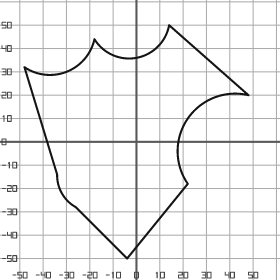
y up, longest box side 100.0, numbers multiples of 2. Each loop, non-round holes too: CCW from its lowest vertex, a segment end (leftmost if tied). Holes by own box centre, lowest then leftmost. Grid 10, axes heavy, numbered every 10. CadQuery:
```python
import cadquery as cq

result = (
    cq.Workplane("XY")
    .moveTo(-4.0, -50.0)
    .lineTo(22.0, -18.0)
    .threePointArc((22.0, 10.0), (48.0, 20.0))
    .lineTo(14.0, 50.0)
    .threePointArc((0.0, 36.0), (-18.0, 44.0))
    .threePointArc((-30.0, 30.0), (-48.0, 32.0))
    .lineTo(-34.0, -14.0)
    .threePointArc((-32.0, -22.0), (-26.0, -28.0))
    .close()
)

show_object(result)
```